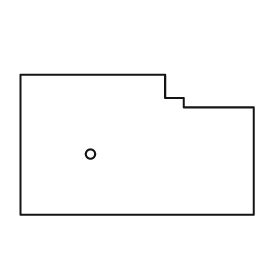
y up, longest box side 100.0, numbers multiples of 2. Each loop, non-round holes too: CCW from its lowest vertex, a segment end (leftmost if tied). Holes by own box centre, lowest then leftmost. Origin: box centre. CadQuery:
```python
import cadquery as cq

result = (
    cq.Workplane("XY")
    .moveTo(-50.0, -30.0)
    .lineTo(50.0, -30.0)
    .lineTo(50.0, 16.0)
    .lineTo(20.0, 16.0)
    .lineTo(20.0, 20.0)
    .lineTo(12.0, 20.0)
    .lineTo(12.0, 30.0)
    .lineTo(-50.0, 30.0)
    .close()
    .moveTo(-20.0, -4.0)
    .circle(2.0)
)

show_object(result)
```